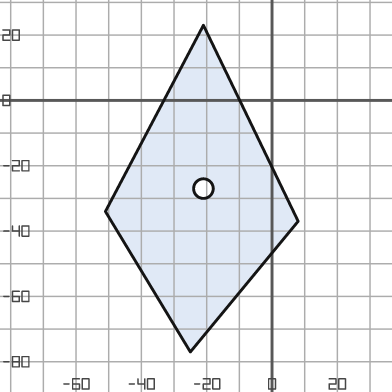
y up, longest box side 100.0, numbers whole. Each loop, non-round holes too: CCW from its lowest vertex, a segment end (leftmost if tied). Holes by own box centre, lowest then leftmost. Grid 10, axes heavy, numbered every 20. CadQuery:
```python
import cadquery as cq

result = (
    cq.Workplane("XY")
    .moveTo(-25.0, -77.0)
    .lineTo(8.0, -37.0)
    .lineTo(-21.0, 23.0)
    .lineTo(-51.0, -34.0)
    .close()
    .moveTo(-21.0, -27.0)
    .circle(3.0)
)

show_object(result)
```